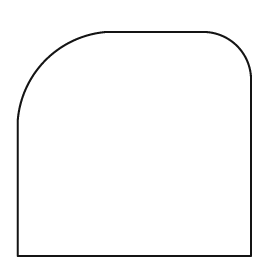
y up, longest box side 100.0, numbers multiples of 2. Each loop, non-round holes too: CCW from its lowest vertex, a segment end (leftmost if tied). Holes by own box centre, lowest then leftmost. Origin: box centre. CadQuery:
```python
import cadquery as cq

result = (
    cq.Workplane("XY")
    .moveTo(-50.0, -48.0)
    .lineTo(50.0, -48.0)
    .lineTo(50.0, 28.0)
    .threePointArc((44.0, 42.0), (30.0, 48.0))
    .lineTo(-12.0, 48.0)
    .threePointArc((-38.0, 36.0), (-50.0, 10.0))
    .close()
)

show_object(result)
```